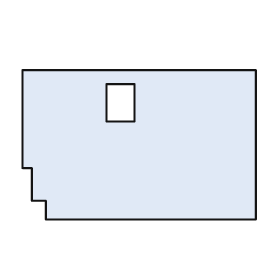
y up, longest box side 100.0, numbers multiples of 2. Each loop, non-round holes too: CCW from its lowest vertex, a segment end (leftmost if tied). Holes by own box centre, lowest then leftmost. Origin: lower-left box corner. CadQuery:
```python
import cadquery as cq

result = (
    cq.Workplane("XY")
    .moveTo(10.0, 0.0)
    .lineTo(100.0, 0.0)
    .lineTo(100.0, 64.0)
    .lineTo(0.0, 64.0)
    .lineTo(0.0, 22.0)
    .lineTo(4.0, 22.0)
    .lineTo(4.0, 8.0)
    .lineTo(10.0, 8.0)
    .close()
    .moveTo(36.0, 42.0)
    .lineTo(48.0, 42.0)
    .lineTo(48.0, 58.0)
    .lineTo(36.0, 58.0)
    .close()
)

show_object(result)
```